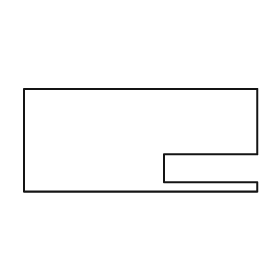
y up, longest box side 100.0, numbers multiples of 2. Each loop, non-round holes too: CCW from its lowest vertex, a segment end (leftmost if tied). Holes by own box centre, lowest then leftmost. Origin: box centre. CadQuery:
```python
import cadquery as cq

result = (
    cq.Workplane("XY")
    .moveTo(-50.0, -22.0)
    .lineTo(50.0, -22.0)
    .lineTo(50.0, -18.0)
    .lineTo(10.0, -18.0)
    .lineTo(10.0, -6.0)
    .lineTo(50.0, -6.0)
    .lineTo(50.0, 22.0)
    .lineTo(-50.0, 22.0)
    .close()
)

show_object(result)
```